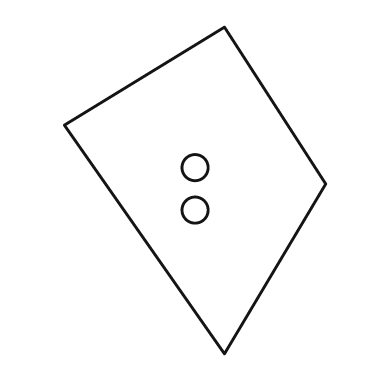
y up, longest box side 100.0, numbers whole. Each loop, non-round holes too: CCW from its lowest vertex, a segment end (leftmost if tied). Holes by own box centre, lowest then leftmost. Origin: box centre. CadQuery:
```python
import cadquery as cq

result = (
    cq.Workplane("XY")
    .moveTo(9.0, -50.0)
    .lineTo(40.0, 2.0)
    .lineTo(9.0, 50.0)
    .lineTo(-40.0, 20.0)
    .close()
    .moveTo(0.0, -6.0)
    .circle(4.0)
    .moveTo(0.0, 7.0)
    .circle(4.0)
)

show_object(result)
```